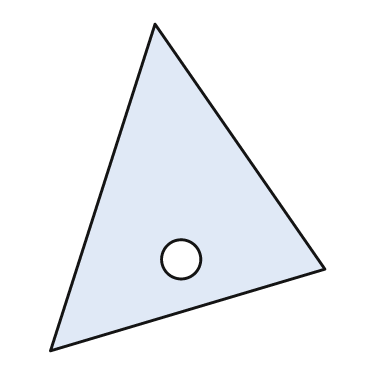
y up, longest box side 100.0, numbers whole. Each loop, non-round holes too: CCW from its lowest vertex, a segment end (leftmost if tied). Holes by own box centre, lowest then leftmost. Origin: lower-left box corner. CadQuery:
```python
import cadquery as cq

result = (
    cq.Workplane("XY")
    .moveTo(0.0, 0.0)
    .lineTo(84.0, 25.0)
    .lineTo(32.0, 100.0)
    .close()
    .moveTo(40.0, 28.0)
    .circle(6.0)
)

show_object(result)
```